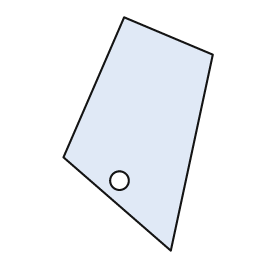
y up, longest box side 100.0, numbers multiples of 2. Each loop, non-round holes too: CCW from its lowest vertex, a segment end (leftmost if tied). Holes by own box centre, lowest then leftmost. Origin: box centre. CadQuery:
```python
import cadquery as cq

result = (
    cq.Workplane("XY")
    .moveTo(14.0, -50.0)
    .lineTo(32.0, 34.0)
    .lineTo(-6.0, 50.0)
    .lineTo(-32.0, -10.0)
    .close()
    .moveTo(-8.0, -20.0)
    .circle(4.0)
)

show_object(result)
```